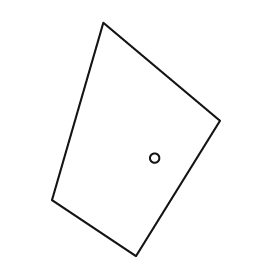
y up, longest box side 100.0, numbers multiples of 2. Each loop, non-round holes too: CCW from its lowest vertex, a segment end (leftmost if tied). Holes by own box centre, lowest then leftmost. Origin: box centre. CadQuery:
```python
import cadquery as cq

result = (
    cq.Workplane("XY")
    .moveTo(0.0, -50.0)
    .lineTo(36.0, 8.0)
    .lineTo(-14.0, 50.0)
    .lineTo(-36.0, -26.0)
    .close()
    .moveTo(8.0, -8.0)
    .circle(2.0)
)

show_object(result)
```